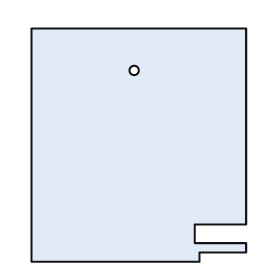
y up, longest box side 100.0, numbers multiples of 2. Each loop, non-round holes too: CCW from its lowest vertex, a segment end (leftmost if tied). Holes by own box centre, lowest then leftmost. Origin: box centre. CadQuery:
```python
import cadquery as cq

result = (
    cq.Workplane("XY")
    .moveTo(-46.0, -50.0)
    .lineTo(26.0, -50.0)
    .lineTo(26.0, -46.0)
    .lineTo(46.0, -46.0)
    .lineTo(46.0, -42.0)
    .lineTo(24.0, -42.0)
    .lineTo(24.0, -34.0)
    .lineTo(46.0, -34.0)
    .lineTo(46.0, 50.0)
    .lineTo(-46.0, 50.0)
    .close()
    .moveTo(-2.0, 32.0)
    .circle(2.0)
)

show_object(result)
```